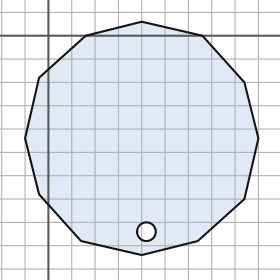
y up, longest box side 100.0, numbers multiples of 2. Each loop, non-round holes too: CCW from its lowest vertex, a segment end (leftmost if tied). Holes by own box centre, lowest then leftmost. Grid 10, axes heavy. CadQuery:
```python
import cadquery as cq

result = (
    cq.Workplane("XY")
    .moveTo(40.0, -94.0)
    .lineTo(64.0, -88.0)
    .lineTo(84.0, -70.0)
    .lineTo(90.0, -44.0)
    .lineTo(84.0, -20.0)
    .lineTo(66.0, 0.0)
    .lineTo(40.0, 6.0)
    .lineTo(16.0, 0.0)
    .lineTo(-4.0, -18.0)
    .lineTo(-10.0, -44.0)
    .lineTo(-4.0, -68.0)
    .lineTo(14.0, -88.0)
    .close()
    .moveTo(42.0, -84.0)
    .circle(4.0)
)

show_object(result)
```